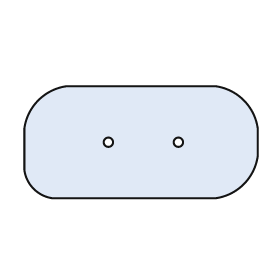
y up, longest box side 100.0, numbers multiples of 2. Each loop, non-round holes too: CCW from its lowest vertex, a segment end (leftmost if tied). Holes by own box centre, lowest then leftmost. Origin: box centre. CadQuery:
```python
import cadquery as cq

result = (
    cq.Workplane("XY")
    .moveTo(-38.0, -24.0)
    .lineTo(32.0, -24.0)
    .threePointArc((44.0, -18.0), (50.0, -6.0))
    .lineTo(50.0, 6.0)
    .threePointArc((44.0, 18.0), (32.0, 24.0))
    .lineTo(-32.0, 24.0)
    .threePointArc((-44.0, 18.0), (-50.0, 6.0))
    .lineTo(-50.0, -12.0)
    .threePointArc((-46.0, -20.0), (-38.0, -24.0))
    .close()
    .moveTo(-14.0, 0.0)
    .circle(2.0)
    .moveTo(16.0, 0.0)
    .circle(2.0)
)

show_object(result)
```